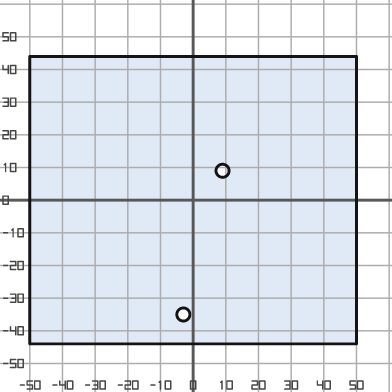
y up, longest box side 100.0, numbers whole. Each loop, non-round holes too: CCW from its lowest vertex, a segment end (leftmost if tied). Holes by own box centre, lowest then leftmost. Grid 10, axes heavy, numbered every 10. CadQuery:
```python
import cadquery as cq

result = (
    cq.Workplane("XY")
    .moveTo(-50.0, -44.0)
    .lineTo(50.0, -44.0)
    .lineTo(50.0, 44.0)
    .lineTo(-50.0, 44.0)
    .close()
    .moveTo(-3.0, -35.0)
    .circle(2.0)
    .moveTo(9.0, 9.0)
    .circle(2.0)
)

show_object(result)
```